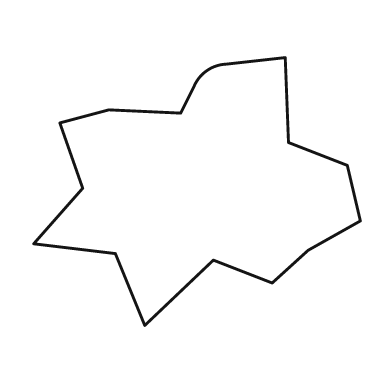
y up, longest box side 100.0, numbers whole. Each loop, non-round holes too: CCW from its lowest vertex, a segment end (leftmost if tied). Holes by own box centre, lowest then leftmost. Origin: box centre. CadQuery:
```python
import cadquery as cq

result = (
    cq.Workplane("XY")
    .moveTo(-16.0, -41.0)
    .lineTo(5.0, -21.0)
    .lineTo(23.0, -28.0)
    .lineTo(34.0, -18.0)
    .lineTo(50.0, -9.0)
    .lineTo(46.0, 8.0)
    .lineTo(28.0, 15.0)
    .lineTo(27.0, 41.0)
    .lineTo(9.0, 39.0)
    .threePointArc((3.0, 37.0), (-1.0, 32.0))
    .lineTo(-5.0, 24.0)
    .lineTo(-27.0, 25.0)
    .lineTo(-42.0, 21.0)
    .lineTo(-35.0, 1.0)
    .lineTo(-50.0, -16.0)
    .lineTo(-25.0, -19.0)
    .close()
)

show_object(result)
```